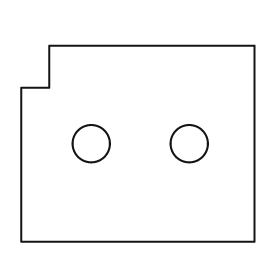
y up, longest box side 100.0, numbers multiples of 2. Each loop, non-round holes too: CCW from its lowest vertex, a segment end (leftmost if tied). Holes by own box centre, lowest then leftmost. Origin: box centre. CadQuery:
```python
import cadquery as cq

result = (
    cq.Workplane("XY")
    .moveTo(-50.0, -42.0)
    .lineTo(50.0, -42.0)
    .lineTo(50.0, 42.0)
    .lineTo(-38.0, 42.0)
    .lineTo(-38.0, 24.0)
    .lineTo(-50.0, 24.0)
    .close()
    .moveTo(-20.0, 0.0)
    .circle(8.0)
    .moveTo(22.0, 0.0)
    .circle(8.0)
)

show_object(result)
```